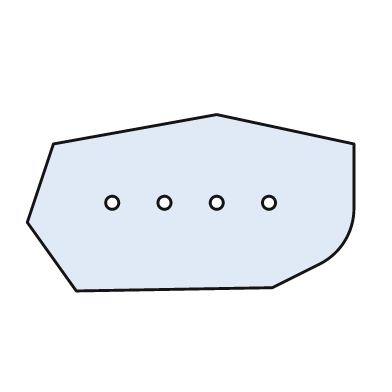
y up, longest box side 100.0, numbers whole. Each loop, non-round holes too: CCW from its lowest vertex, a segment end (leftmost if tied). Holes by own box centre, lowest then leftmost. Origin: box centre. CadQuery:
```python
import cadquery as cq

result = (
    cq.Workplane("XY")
    .moveTo(-35.0, -27.0)
    .lineTo(25.0, -26.0)
    .lineTo(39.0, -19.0)
    .threePointArc((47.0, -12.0), (50.0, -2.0))
    .lineTo(50.0, 18.0)
    .lineTo(8.0, 27.0)
    .lineTo(-42.0, 18.0)
    .lineTo(-50.0, -6.0)
    .close()
    .moveTo(-24.0, 0.0)
    .circle(2.0)
    .moveTo(-8.0, 0.0)
    .circle(2.0)
    .moveTo(8.0, 0.0)
    .circle(2.0)
    .moveTo(24.0, 0.0)
    .circle(2.0)
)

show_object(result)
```